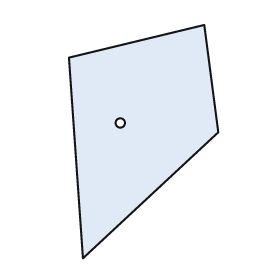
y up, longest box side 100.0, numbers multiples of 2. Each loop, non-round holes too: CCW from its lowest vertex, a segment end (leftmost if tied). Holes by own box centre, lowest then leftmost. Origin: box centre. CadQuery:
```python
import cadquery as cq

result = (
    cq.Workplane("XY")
    .moveTo(-26.0, -50.0)
    .lineTo(32.0, 4.0)
    .lineTo(26.0, 50.0)
    .lineTo(-32.0, 36.0)
    .close()
    .moveTo(-10.0, 8.0)
    .circle(2.0)
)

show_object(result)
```